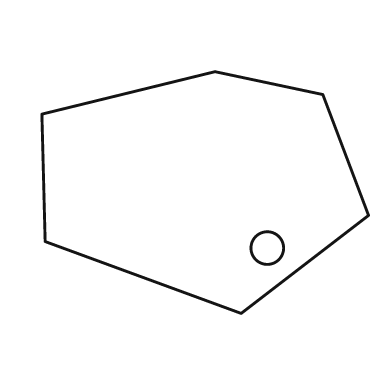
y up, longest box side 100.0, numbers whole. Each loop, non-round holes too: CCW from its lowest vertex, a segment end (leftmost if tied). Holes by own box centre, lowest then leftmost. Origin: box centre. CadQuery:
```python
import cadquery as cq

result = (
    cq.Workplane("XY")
    .moveTo(11.0, -37.0)
    .lineTo(50.0, -7.0)
    .lineTo(36.0, 30.0)
    .lineTo(3.0, 37.0)
    .lineTo(-50.0, 24.0)
    .lineTo(-49.0, -15.0)
    .close()
    .moveTo(19.0, -17.0)
    .circle(5.0)
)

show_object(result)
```